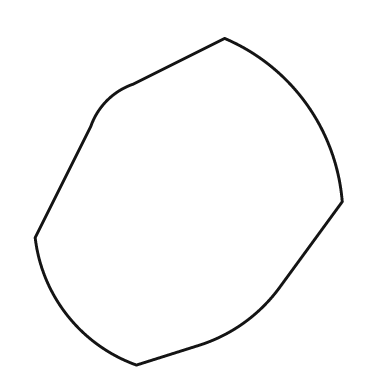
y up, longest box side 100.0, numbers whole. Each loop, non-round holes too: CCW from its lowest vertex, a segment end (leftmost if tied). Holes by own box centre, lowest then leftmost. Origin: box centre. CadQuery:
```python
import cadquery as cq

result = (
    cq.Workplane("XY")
    .moveTo(-16.0, -50.0)
    .lineTo(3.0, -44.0)
    .threePointArc((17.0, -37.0), (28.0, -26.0))
    .lineTo(47.0, 0.0)
    .threePointArc((36.0, 30.0), (11.0, 50.0))
    .lineTo(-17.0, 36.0)
    .threePointArc((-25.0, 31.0), (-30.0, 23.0))
    .lineTo(-47.0, -11.0)
    .threePointArc((-37.0, -35.0), (-16.0, -50.0))
    .close()
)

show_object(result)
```